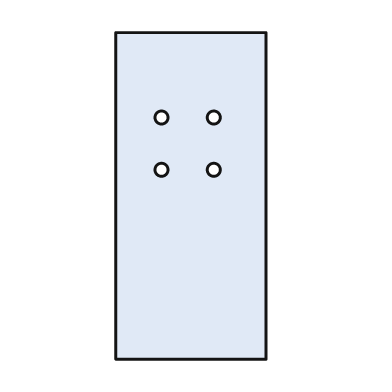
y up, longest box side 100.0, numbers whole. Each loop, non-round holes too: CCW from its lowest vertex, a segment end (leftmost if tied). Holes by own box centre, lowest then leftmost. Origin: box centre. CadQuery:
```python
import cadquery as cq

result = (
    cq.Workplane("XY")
    .moveTo(-23.0, -50.0)
    .lineTo(23.0, -50.0)
    .lineTo(23.0, 50.0)
    .lineTo(-23.0, 50.0)
    .close()
    .moveTo(-9.0, 8.0)
    .circle(2.0)
    .moveTo(7.0, 8.0)
    .circle(2.0)
    .moveTo(-9.0, 24.0)
    .circle(2.0)
    .moveTo(7.0, 24.0)
    .circle(2.0)
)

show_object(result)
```